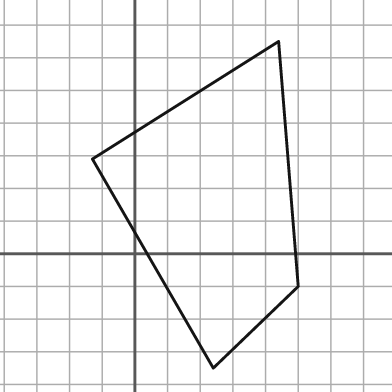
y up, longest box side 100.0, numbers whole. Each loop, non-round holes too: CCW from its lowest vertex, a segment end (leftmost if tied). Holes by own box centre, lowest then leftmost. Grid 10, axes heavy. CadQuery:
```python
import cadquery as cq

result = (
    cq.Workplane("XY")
    .moveTo(24.0, -35.0)
    .lineTo(50.0, -10.0)
    .lineTo(44.0, 65.0)
    .lineTo(-13.0, 29.0)
    .close()
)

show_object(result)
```